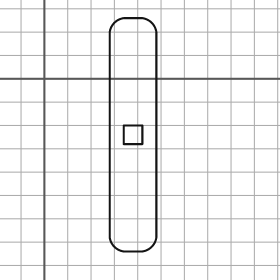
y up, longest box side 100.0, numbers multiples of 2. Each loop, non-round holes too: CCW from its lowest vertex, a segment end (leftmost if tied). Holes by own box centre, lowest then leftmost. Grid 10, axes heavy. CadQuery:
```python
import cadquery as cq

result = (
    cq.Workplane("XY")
    .moveTo(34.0, -74.0)
    .lineTo(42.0, -74.0)
    .threePointArc((46.0, -72.0), (48.0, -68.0))
    .lineTo(48.0, 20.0)
    .threePointArc((46.0, 24.0), (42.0, 26.0))
    .lineTo(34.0, 26.0)
    .threePointArc((30.0, 24.0), (28.0, 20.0))
    .lineTo(28.0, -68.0)
    .threePointArc((30.0, -72.0), (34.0, -74.0))
    .close()
    .moveTo(34.0, -28.0)
    .lineTo(42.0, -28.0)
    .lineTo(42.0, -20.0)
    .lineTo(34.0, -20.0)
    .close()
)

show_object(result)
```